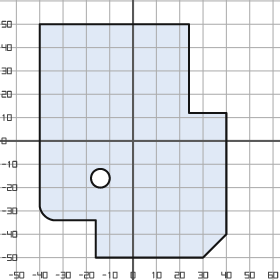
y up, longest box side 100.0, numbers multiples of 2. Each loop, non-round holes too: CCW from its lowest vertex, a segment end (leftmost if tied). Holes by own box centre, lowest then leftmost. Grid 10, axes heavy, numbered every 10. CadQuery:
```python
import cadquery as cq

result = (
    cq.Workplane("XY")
    .moveTo(-16.0, -50.0)
    .lineTo(30.0, -50.0)
    .lineTo(40.0, -40.0)
    .lineTo(40.0, 12.0)
    .lineTo(24.0, 12.0)
    .lineTo(24.0, 50.0)
    .lineTo(-40.0, 50.0)
    .lineTo(-40.0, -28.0)
    .threePointArc((-38.0, -32.0), (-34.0, -34.0))
    .lineTo(-16.0, -34.0)
    .close()
    .moveTo(-14.0, -16.0)
    .circle(4.0)
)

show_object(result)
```